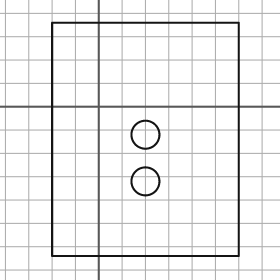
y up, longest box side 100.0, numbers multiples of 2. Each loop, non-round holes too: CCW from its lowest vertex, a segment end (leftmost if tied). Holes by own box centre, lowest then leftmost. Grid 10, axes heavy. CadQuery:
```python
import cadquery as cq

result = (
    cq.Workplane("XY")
    .moveTo(-20.0, -64.0)
    .lineTo(60.0, -64.0)
    .lineTo(60.0, 36.0)
    .lineTo(-20.0, 36.0)
    .close()
    .moveTo(20.0, -32.0)
    .circle(6.0)
    .moveTo(20.0, -12.0)
    .circle(6.0)
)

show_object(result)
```